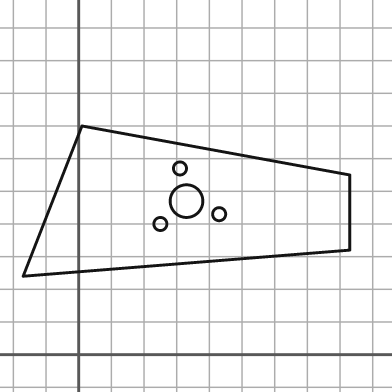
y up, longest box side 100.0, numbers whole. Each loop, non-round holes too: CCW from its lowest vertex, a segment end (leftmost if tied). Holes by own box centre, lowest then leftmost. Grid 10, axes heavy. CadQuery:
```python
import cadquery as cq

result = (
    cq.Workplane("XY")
    .moveTo(-17.0, 24.0)
    .lineTo(83.0, 32.0)
    .lineTo(83.0, 55.0)
    .lineTo(1.0, 70.0)
    .close()
    .moveTo(25.0, 40.0)
    .circle(2.0)
    .moveTo(43.0, 43.0)
    .circle(2.0)
    .moveTo(33.0, 47.0)
    .circle(5.0)
    .moveTo(31.0, 57.0)
    .circle(2.0)
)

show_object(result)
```